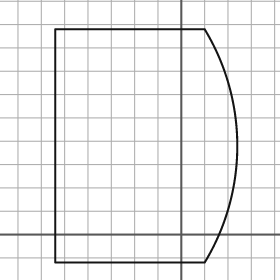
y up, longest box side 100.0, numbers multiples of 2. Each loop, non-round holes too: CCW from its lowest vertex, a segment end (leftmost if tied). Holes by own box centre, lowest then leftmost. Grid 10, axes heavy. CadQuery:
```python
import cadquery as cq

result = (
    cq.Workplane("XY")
    .moveTo(-54.0, -12.0)
    .lineTo(10.0, -12.0)
    .threePointArc((24.0, 38.0), (10.0, 88.0))
    .lineTo(-54.0, 88.0)
    .close()
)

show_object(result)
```